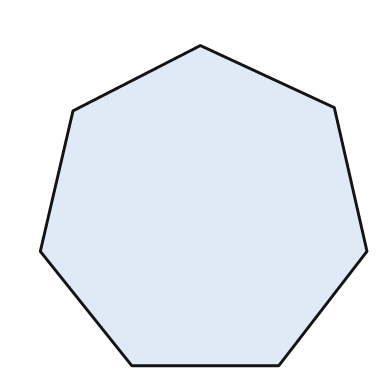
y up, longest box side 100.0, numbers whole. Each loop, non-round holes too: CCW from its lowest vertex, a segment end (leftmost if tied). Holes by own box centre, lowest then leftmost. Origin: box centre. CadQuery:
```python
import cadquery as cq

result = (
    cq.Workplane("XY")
    .moveTo(-22.0, -49.0)
    .lineTo(23.0, -49.0)
    .lineTo(50.0, -14.0)
    .lineTo(40.0, 30.0)
    .lineTo(-1.0, 49.0)
    .lineTo(-40.0, 29.0)
    .lineTo(-50.0, -14.0)
    .close()
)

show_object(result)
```